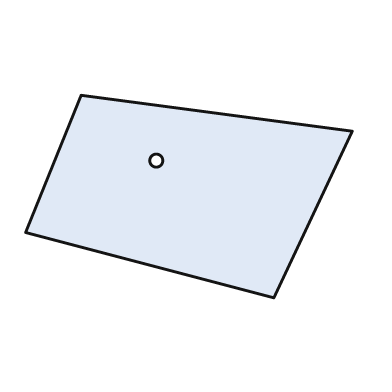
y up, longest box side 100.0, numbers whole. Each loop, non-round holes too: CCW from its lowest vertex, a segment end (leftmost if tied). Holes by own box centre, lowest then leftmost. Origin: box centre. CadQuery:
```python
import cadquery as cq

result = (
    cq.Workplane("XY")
    .moveTo(26.0, -31.0)
    .lineTo(50.0, 20.0)
    .lineTo(-33.0, 31.0)
    .lineTo(-50.0, -11.0)
    .close()
    .moveTo(-10.0, 11.0)
    .circle(2.0)
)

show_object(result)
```